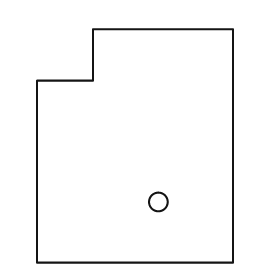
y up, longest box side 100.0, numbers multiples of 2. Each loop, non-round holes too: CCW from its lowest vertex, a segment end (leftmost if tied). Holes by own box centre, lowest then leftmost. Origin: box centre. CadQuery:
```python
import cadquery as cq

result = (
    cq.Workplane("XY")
    .moveTo(-42.0, -50.0)
    .lineTo(42.0, -50.0)
    .lineTo(42.0, 50.0)
    .lineTo(-18.0, 50.0)
    .lineTo(-18.0, 28.0)
    .lineTo(-42.0, 28.0)
    .close()
    .moveTo(10.0, -24.0)
    .circle(4.0)
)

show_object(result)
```